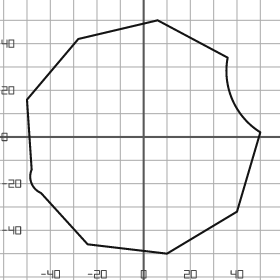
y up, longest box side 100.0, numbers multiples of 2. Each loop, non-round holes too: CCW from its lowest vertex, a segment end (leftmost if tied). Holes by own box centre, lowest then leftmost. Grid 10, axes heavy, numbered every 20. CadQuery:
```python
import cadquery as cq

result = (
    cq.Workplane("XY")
    .moveTo(10.0, -50.0)
    .lineTo(40.0, -32.0)
    .lineTo(50.0, 2.0)
    .threePointArc((38.0, 16.0), (36.0, 34.0))
    .lineTo(6.0, 50.0)
    .lineTo(-28.0, 42.0)
    .lineTo(-50.0, 16.0)
    .lineTo(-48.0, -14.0)
    .threePointArc((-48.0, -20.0), (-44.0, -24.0))
    .lineTo(-24.0, -46.0)
    .close()
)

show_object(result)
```